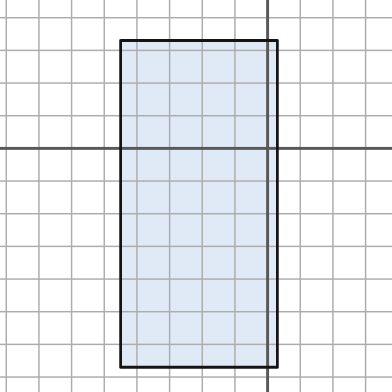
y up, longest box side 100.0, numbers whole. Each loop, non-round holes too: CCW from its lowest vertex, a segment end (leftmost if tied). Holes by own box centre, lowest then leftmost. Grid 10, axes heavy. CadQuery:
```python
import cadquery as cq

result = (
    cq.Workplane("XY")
    .moveTo(-45.0, -67.0)
    .lineTo(3.0, -67.0)
    .lineTo(3.0, 33.0)
    .lineTo(-45.0, 33.0)
    .close()
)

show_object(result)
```